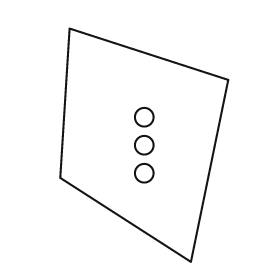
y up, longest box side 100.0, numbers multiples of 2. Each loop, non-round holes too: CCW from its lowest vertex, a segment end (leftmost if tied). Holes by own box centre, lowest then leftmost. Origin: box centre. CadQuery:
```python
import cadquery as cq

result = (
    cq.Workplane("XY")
    .moveTo(20.0, -50.0)
    .lineTo(36.0, 28.0)
    .lineTo(-32.0, 50.0)
    .lineTo(-36.0, -14.0)
    .close()
    .moveTo(0.0, -12.0)
    .circle(4.0)
    .moveTo(0.0, 0.0)
    .circle(4.0)
    .moveTo(0.0, 12.0)
    .circle(4.0)
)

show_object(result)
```